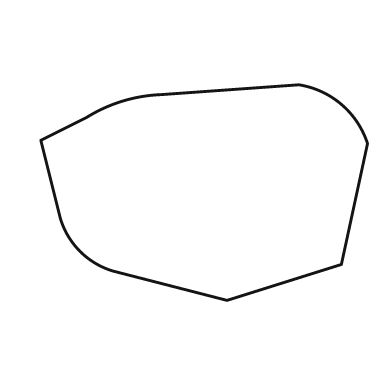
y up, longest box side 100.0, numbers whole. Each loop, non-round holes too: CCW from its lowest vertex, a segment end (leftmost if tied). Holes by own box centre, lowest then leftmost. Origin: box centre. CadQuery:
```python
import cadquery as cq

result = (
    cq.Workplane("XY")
    .moveTo(7.0, -33.0)
    .lineTo(42.0, -22.0)
    .lineTo(50.0, 15.0)
    .threePointArc((42.0, 27.0), (29.0, 33.0))
    .lineTo(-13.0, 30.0)
    .threePointArc((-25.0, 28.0), (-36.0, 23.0))
    .lineTo(-50.0, 16.0)
    .lineTo(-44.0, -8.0)
    .threePointArc((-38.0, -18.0), (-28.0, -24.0))
    .close()
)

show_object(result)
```